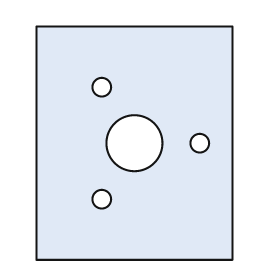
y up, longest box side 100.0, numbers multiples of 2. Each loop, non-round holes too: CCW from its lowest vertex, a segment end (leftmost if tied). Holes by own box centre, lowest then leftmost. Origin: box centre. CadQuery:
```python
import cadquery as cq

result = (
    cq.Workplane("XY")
    .moveTo(-42.0, -50.0)
    .lineTo(42.0, -50.0)
    .lineTo(42.0, 50.0)
    .lineTo(-42.0, 50.0)
    .close()
    .moveTo(-14.0, -24.0)
    .circle(4.0)
    .moveTo(0.0, 0.0)
    .circle(12.0)
    .moveTo(28.0, 0.0)
    .circle(4.0)
    .moveTo(-14.0, 24.0)
    .circle(4.0)
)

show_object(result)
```